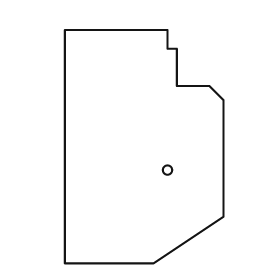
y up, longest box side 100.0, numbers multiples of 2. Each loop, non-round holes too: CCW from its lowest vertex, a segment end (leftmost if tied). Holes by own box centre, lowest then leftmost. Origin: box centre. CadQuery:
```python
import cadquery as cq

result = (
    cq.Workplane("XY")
    .moveTo(-34.0, -50.0)
    .lineTo(4.0, -50.0)
    .lineTo(34.0, -30.0)
    .lineTo(34.0, 20.0)
    .lineTo(28.0, 26.0)
    .lineTo(14.0, 26.0)
    .lineTo(14.0, 42.0)
    .lineTo(10.0, 42.0)
    .lineTo(10.0, 50.0)
    .lineTo(-34.0, 50.0)
    .close()
    .moveTo(10.0, -10.0)
    .circle(2.0)
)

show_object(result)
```